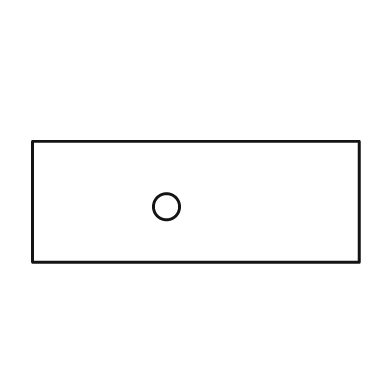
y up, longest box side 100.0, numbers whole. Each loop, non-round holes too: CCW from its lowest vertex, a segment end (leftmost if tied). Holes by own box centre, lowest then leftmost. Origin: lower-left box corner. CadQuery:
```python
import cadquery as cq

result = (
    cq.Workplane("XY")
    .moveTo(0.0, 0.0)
    .lineTo(100.0, 0.0)
    .lineTo(100.0, 37.0)
    .lineTo(0.0, 37.0)
    .close()
    .moveTo(41.0, 17.0)
    .circle(4.0)
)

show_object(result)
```